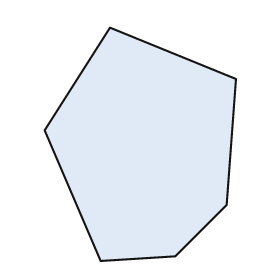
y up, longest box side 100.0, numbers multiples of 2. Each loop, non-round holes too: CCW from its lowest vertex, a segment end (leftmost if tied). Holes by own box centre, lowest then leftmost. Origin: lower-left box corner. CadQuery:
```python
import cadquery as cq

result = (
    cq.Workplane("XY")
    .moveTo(24.0, 0.0)
    .lineTo(56.0, 2.0)
    .lineTo(78.0, 24.0)
    .lineTo(82.0, 78.0)
    .lineTo(28.0, 100.0)
    .lineTo(0.0, 56.0)
    .close()
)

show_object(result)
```